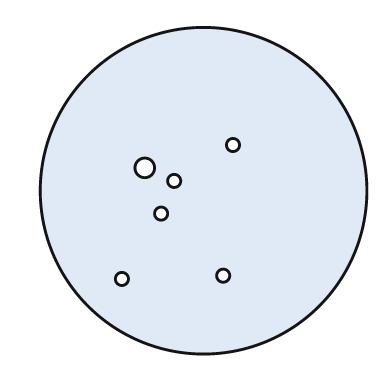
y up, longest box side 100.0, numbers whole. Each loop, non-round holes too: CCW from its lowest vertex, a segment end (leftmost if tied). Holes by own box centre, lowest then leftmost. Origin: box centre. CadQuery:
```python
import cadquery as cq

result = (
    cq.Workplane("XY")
    .moveTo(0.0, 0.0)
    .circle(50.0)
    .moveTo(-25.0, -27.0)
    .circle(2.0)
    .moveTo(6.0, -26.0)
    .circle(2.0)
    .moveTo(-13.0, -7.0)
    .circle(2.0)
    .moveTo(-9.0, 3.0)
    .circle(2.0)
    .moveTo(-18.0, 7.0)
    .circle(3.0)
    .moveTo(9.0, 14.0)
    .circle(2.0)
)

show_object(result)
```